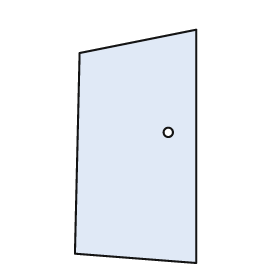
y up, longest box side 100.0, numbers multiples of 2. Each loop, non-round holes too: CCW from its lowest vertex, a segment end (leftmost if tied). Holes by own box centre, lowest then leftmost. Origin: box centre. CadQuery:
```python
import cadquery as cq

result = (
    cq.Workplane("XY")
    .moveTo(26.0, -50.0)
    .lineTo(26.0, 50.0)
    .lineTo(-24.0, 40.0)
    .lineTo(-26.0, -46.0)
    .close()
    .moveTo(14.0, 6.0)
    .circle(2.0)
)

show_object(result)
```